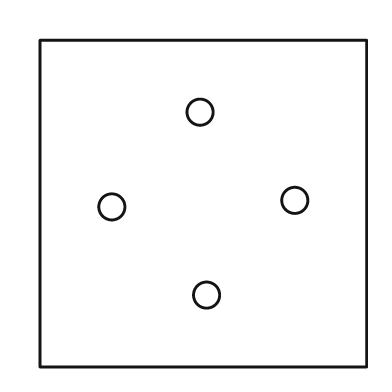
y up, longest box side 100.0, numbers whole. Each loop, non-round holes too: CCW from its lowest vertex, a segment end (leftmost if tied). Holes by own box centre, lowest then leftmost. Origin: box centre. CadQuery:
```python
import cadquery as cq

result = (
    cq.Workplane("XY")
    .moveTo(-50.0, -50.0)
    .lineTo(50.0, -50.0)
    .lineTo(50.0, 50.0)
    .lineTo(-50.0, 50.0)
    .close()
    .moveTo(1.0, -28.0)
    .circle(4.0)
    .moveTo(-28.0, -1.0)
    .circle(4.0)
    .moveTo(28.0, 1.0)
    .circle(4.0)
    .moveTo(-1.0, 28.0)
    .circle(4.0)
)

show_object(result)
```